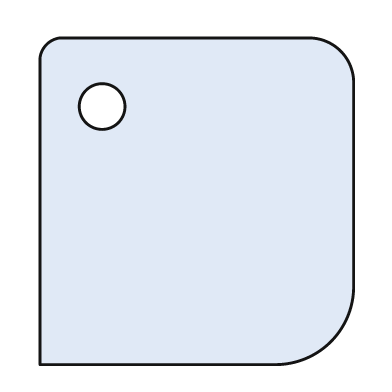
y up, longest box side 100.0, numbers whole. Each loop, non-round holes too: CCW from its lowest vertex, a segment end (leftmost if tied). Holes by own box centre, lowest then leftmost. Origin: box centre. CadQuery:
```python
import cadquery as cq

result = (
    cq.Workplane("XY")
    .moveTo(-48.0, -50.0)
    .lineTo(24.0, -50.0)
    .threePointArc((41.0, -43.0), (48.0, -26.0))
    .lineTo(48.0, 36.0)
    .threePointArc((44.0, 46.0), (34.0, 50.0))
    .lineTo(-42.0, 50.0)
    .threePointArc((-46.0, 48.0), (-48.0, 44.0))
    .close()
    .moveTo(-29.0, 29.0)
    .circle(7.0)
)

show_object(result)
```